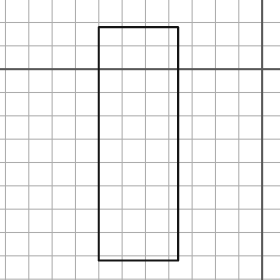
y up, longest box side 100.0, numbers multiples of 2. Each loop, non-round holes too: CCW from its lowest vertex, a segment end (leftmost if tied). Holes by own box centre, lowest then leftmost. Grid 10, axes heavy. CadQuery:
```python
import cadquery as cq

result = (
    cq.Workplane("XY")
    .moveTo(-70.0, -82.0)
    .lineTo(-36.0, -82.0)
    .lineTo(-36.0, 18.0)
    .lineTo(-70.0, 18.0)
    .close()
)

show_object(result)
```